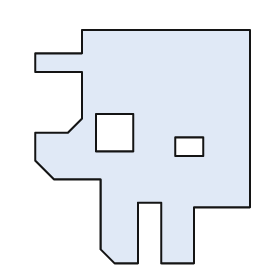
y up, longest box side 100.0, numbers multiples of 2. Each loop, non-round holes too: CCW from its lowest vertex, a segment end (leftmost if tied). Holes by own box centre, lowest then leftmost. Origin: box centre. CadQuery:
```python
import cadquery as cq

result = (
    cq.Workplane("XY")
    .moveTo(-12.0, -50.0)
    .lineTo(-2.0, -50.0)
    .lineTo(-2.0, -24.0)
    .lineTo(8.0, -24.0)
    .lineTo(8.0, -50.0)
    .lineTo(22.0, -50.0)
    .lineTo(22.0, -26.0)
    .lineTo(46.0, -26.0)
    .lineTo(46.0, 50.0)
    .lineTo(-26.0, 50.0)
    .lineTo(-26.0, 40.0)
    .lineTo(-46.0, 40.0)
    .lineTo(-46.0, 32.0)
    .lineTo(-26.0, 32.0)
    .lineTo(-26.0, 12.0)
    .lineTo(-32.0, 6.0)
    .lineTo(-46.0, 6.0)
    .lineTo(-46.0, -6.0)
    .lineTo(-38.0, -14.0)
    .lineTo(-18.0, -14.0)
    .lineTo(-18.0, -44.0)
    .close()
    .moveTo(14.0, -4.0)
    .lineTo(26.0, -4.0)
    .lineTo(26.0, 4.0)
    .lineTo(14.0, 4.0)
    .close()
    .moveTo(-20.0, -2.0)
    .lineTo(-4.0, -2.0)
    .lineTo(-4.0, 14.0)
    .lineTo(-20.0, 14.0)
    .close()
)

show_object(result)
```